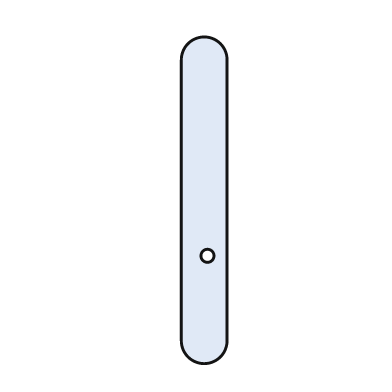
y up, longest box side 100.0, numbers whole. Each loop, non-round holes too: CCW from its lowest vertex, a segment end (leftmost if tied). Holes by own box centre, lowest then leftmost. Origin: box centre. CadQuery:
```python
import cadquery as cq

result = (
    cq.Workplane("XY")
    .moveTo(-7.0, -43.0)
    .threePointArc((0.0, -50.0), (7.0, -43.0))
    .lineTo(7.0, 43.0)
    .threePointArc((0.0, 50.0), (-7.0, 43.0))
    .close()
    .moveTo(1.0, -17.0)
    .circle(2.0)
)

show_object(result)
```